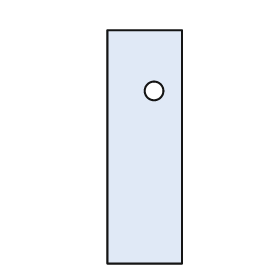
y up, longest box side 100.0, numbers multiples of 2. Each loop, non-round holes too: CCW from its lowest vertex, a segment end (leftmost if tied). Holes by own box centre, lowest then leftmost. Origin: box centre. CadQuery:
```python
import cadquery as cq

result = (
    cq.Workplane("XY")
    .moveTo(-16.0, -50.0)
    .lineTo(16.0, -50.0)
    .lineTo(16.0, 50.0)
    .lineTo(-16.0, 50.0)
    .close()
    .moveTo(4.0, 24.0)
    .circle(4.0)
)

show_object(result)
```